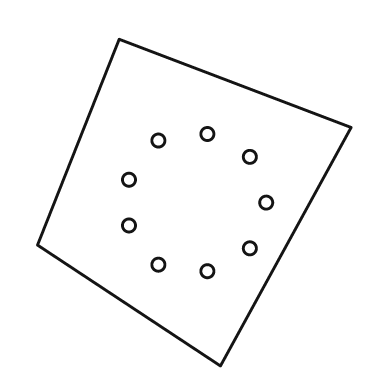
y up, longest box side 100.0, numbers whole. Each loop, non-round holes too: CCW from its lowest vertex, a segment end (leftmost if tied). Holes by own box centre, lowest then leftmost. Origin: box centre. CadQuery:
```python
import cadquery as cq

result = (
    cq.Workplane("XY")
    .moveTo(8.0, -50.0)
    .lineTo(48.0, 23.0)
    .lineTo(-23.0, 50.0)
    .lineTo(-48.0, -13.0)
    .close()
    .moveTo(4.0, -21.0)
    .circle(2.0)
    .moveTo(-11.0, -19.0)
    .circle(2.0)
    .moveTo(17.0, -14.0)
    .circle(2.0)
    .moveTo(-20.0, -7.0)
    .circle(2.0)
    .moveTo(22.0, 0.0)
    .circle(2.0)
    .moveTo(-20.0, 7.0)
    .circle(2.0)
    .moveTo(17.0, 14.0)
    .circle(2.0)
    .moveTo(-11.0, 19.0)
    .circle(2.0)
    .moveTo(4.0, 21.0)
    .circle(2.0)
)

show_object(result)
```